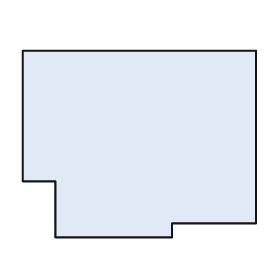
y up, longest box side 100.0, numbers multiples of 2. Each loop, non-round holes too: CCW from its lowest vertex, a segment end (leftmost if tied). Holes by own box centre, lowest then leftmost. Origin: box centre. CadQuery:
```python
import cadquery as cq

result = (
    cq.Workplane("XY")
    .moveTo(-36.0, -40.0)
    .lineTo(14.0, -40.0)
    .lineTo(14.0, -34.0)
    .lineTo(50.0, -34.0)
    .lineTo(50.0, 40.0)
    .lineTo(-50.0, 40.0)
    .lineTo(-50.0, -16.0)
    .lineTo(-36.0, -16.0)
    .close()
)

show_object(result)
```